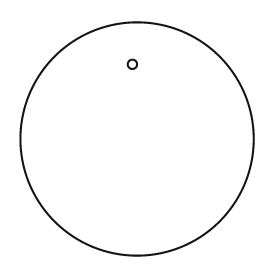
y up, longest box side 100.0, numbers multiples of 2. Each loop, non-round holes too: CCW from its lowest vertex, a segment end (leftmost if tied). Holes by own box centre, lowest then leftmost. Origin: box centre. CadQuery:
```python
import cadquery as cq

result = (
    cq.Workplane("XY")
    .moveTo(0.0, 0.0)
    .circle(50.0)
    .moveTo(-2.0, 32.0)
    .circle(2.0)
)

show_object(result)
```